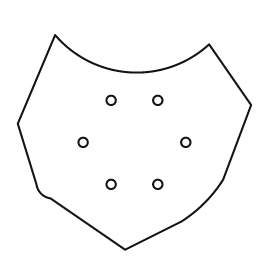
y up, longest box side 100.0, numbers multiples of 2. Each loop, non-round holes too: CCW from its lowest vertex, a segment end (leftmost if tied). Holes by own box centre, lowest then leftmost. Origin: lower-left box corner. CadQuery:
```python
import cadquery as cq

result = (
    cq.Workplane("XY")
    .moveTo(46.0, 0.0)
    .lineTo(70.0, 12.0)
    .threePointArc((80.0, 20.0), (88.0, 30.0))
    .lineTo(100.0, 62.0)
    .lineTo(82.0, 88.0)
    .threePointArc((48.0, 76.0), (16.0, 92.0))
    .lineTo(0.0, 54.0)
    .lineTo(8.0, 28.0)
    .threePointArc((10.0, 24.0), (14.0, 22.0))
    .close()
    .moveTo(40.0, 28.0)
    .circle(2.0)
    .moveTo(60.0, 28.0)
    .circle(2.0)
    .moveTo(28.0, 46.0)
    .circle(2.0)
    .moveTo(72.0, 46.0)
    .circle(2.0)
    .moveTo(40.0, 64.0)
    .circle(2.0)
    .moveTo(60.0, 64.0)
    .circle(2.0)
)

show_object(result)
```